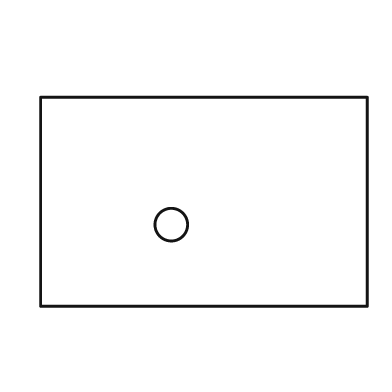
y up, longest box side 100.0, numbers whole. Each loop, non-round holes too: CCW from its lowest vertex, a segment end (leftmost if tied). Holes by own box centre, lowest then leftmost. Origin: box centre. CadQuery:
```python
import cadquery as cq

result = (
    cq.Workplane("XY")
    .moveTo(-50.0, -32.0)
    .lineTo(50.0, -32.0)
    .lineTo(50.0, 32.0)
    .lineTo(-50.0, 32.0)
    .close()
    .moveTo(-10.0, -7.0)
    .circle(5.0)
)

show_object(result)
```